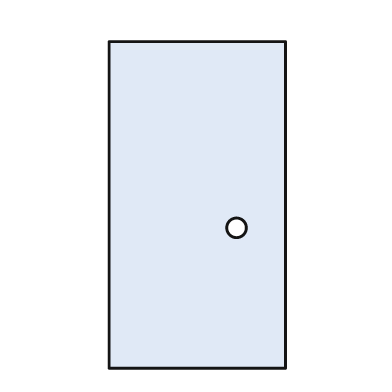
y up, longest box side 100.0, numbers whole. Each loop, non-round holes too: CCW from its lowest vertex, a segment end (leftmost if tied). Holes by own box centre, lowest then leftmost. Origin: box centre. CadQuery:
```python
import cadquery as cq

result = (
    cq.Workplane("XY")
    .moveTo(-27.0, -50.0)
    .lineTo(27.0, -50.0)
    .lineTo(27.0, 50.0)
    .lineTo(-27.0, 50.0)
    .close()
    .moveTo(12.0, -7.0)
    .circle(3.0)
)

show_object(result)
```